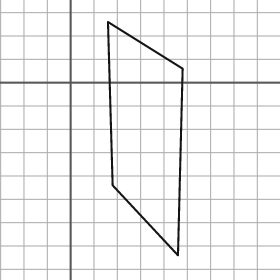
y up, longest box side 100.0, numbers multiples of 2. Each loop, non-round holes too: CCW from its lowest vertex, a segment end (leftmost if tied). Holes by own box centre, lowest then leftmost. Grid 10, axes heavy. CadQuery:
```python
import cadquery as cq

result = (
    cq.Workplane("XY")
    .moveTo(46.0, -74.0)
    .lineTo(48.0, 6.0)
    .lineTo(16.0, 26.0)
    .lineTo(18.0, -44.0)
    .close()
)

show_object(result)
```